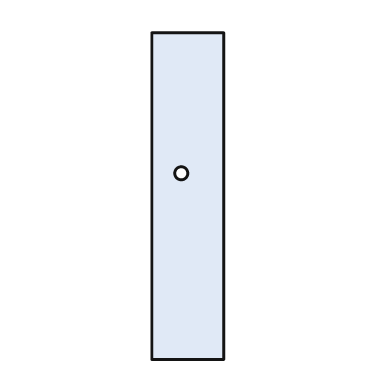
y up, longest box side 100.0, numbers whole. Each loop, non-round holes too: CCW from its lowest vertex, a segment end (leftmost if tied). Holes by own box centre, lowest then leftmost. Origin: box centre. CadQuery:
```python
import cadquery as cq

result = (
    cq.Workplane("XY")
    .moveTo(-11.0, -50.0)
    .lineTo(11.0, -50.0)
    .lineTo(11.0, 50.0)
    .lineTo(-11.0, 50.0)
    .close()
    .moveTo(-2.0, 7.0)
    .circle(2.0)
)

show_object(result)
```